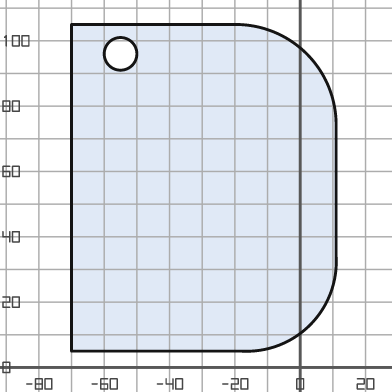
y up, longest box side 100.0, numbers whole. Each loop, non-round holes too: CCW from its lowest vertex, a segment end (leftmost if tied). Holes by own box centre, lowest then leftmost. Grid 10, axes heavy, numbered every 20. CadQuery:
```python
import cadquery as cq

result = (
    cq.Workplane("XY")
    .moveTo(-70.0, 5.0)
    .lineTo(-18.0, 5.0)
    .threePointArc((3.0, 13.0), (11.0, 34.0))
    .lineTo(11.0, 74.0)
    .threePointArc((2.0, 96.0), (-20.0, 105.0))
    .lineTo(-70.0, 105.0)
    .close()
    .moveTo(-55.0, 96.0)
    .circle(5.0)
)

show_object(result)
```